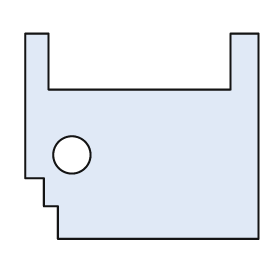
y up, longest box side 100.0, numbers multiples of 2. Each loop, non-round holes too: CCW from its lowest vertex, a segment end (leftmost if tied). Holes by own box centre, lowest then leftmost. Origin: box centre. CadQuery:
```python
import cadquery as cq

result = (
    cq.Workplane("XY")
    .moveTo(-36.0, -44.0)
    .lineTo(50.0, -44.0)
    .lineTo(50.0, 44.0)
    .lineTo(38.0, 44.0)
    .lineTo(38.0, 20.0)
    .lineTo(-40.0, 20.0)
    .lineTo(-40.0, 44.0)
    .lineTo(-50.0, 44.0)
    .lineTo(-50.0, -18.0)
    .lineTo(-42.0, -18.0)
    .lineTo(-42.0, -30.0)
    .lineTo(-36.0, -30.0)
    .close()
    .moveTo(-30.0, -8.0)
    .circle(8.0)
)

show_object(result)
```